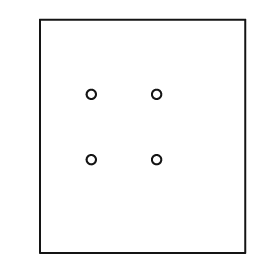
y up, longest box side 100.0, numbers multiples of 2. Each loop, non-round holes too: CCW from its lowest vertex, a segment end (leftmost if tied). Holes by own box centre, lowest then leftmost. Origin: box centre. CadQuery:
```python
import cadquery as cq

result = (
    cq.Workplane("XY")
    .moveTo(-44.0, -50.0)
    .lineTo(44.0, -50.0)
    .lineTo(44.0, 50.0)
    .lineTo(-44.0, 50.0)
    .close()
    .moveTo(-22.0, -10.0)
    .circle(2.0)
    .moveTo(6.0, -10.0)
    .circle(2.0)
    .moveTo(-22.0, 18.0)
    .circle(2.0)
    .moveTo(6.0, 18.0)
    .circle(2.0)
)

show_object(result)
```